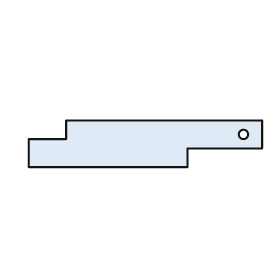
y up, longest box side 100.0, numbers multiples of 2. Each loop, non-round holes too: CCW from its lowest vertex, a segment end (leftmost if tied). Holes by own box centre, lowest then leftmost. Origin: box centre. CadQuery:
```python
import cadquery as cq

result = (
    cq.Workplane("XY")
    .moveTo(-50.0, -10.0)
    .lineTo(18.0, -10.0)
    .lineTo(18.0, -2.0)
    .lineTo(50.0, -2.0)
    .lineTo(50.0, 10.0)
    .lineTo(-34.0, 10.0)
    .lineTo(-34.0, 2.0)
    .lineTo(-50.0, 2.0)
    .close()
    .moveTo(42.0, 4.0)
    .circle(2.0)
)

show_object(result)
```